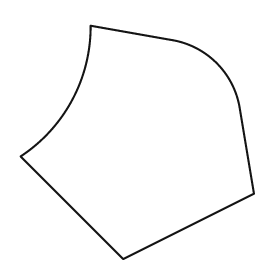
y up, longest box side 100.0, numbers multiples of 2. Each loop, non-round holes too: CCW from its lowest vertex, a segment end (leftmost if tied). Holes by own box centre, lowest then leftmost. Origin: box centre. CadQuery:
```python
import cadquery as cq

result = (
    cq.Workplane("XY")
    .moveTo(-6.0, -50.0)
    .lineTo(50.0, -22.0)
    .lineTo(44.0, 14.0)
    .threePointArc((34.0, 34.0), (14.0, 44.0))
    .lineTo(-20.0, 50.0)
    .threePointArc((-28.0, 18.0), (-50.0, -6.0))
    .close()
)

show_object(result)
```